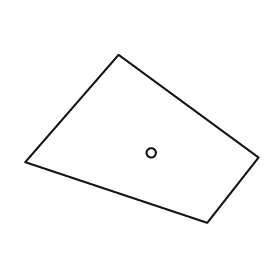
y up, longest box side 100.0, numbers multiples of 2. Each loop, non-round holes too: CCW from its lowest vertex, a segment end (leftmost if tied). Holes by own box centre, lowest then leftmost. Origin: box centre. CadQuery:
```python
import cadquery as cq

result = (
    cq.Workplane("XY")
    .moveTo(28.0, -36.0)
    .lineTo(50.0, -8.0)
    .lineTo(-10.0, 36.0)
    .lineTo(-50.0, -10.0)
    .close()
    .moveTo(4.0, -6.0)
    .circle(2.0)
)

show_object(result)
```